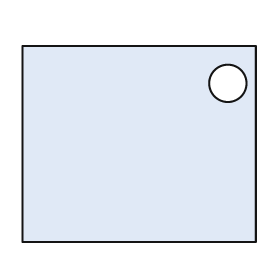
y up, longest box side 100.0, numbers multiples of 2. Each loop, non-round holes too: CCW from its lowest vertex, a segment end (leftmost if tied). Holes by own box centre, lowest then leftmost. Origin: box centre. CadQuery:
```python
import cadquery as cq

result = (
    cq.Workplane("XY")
    .moveTo(-50.0, -42.0)
    .lineTo(50.0, -42.0)
    .lineTo(50.0, 42.0)
    .lineTo(-50.0, 42.0)
    .close()
    .moveTo(38.0, 26.0)
    .circle(8.0)
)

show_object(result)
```